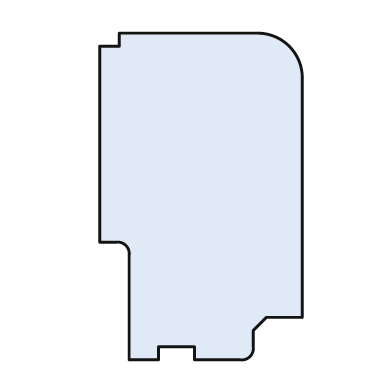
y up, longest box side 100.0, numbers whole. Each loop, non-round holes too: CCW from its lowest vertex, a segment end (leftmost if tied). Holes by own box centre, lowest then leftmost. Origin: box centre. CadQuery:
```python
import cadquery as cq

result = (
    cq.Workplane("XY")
    .moveTo(-22.0, -50.0)
    .lineTo(-13.0, -50.0)
    .lineTo(-13.0, -46.0)
    .lineTo(-2.0, -46.0)
    .lineTo(-2.0, -50.0)
    .lineTo(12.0, -50.0)
    .threePointArc((15.0, -49.0), (16.0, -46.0))
    .lineTo(16.0, -41.0)
    .lineTo(20.0, -37.0)
    .lineTo(31.0, -37.0)
    .lineTo(31.0, 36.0)
    .threePointArc((27.0, 46.0), (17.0, 50.0))
    .lineTo(-25.0, 50.0)
    .lineTo(-25.0, 46.0)
    .lineTo(-31.0, 46.0)
    .lineTo(-31.0, -14.0)
    .lineTo(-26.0, -14.0)
    .threePointArc((-23.0, -15.0), (-22.0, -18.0))
    .close()
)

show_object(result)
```